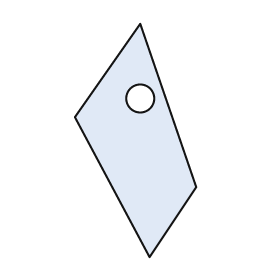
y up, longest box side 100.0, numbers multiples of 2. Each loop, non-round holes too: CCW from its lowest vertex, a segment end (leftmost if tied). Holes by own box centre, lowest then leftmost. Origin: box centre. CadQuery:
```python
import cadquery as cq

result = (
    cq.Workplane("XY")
    .moveTo(6.0, -50.0)
    .lineTo(26.0, -20.0)
    .lineTo(2.0, 50.0)
    .lineTo(-26.0, 10.0)
    .close()
    .moveTo(2.0, 18.0)
    .circle(6.0)
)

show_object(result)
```